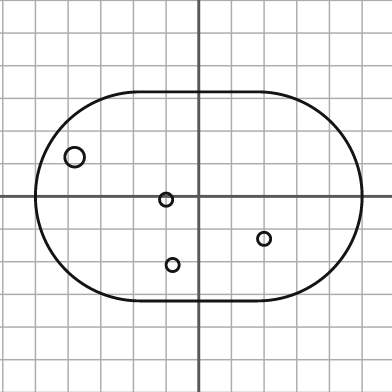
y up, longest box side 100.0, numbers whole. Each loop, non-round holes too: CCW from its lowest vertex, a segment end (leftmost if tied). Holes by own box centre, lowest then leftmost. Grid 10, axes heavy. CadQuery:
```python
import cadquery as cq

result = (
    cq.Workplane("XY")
    .moveTo(-18.0, -32.0)
    .lineTo(18.0, -32.0)
    .threePointArc((50.0, 0.0), (18.0, 32.0))
    .lineTo(-18.0, 32.0)
    .threePointArc((-50.0, 0.0), (-18.0, -32.0))
    .close()
    .moveTo(-8.0, -21.0)
    .circle(2.0)
    .moveTo(20.0, -13.0)
    .circle(2.0)
    .moveTo(-10.0, -1.0)
    .circle(2.0)
    .moveTo(-38.0, 12.0)
    .circle(3.0)
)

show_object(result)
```